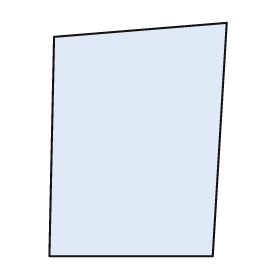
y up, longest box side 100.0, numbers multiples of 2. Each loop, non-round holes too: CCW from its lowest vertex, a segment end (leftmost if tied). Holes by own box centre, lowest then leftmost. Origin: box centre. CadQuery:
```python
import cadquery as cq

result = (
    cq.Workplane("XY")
    .moveTo(-38.0, -50.0)
    .lineTo(32.0, -50.0)
    .lineTo(38.0, 50.0)
    .lineTo(-36.0, 44.0)
    .close()
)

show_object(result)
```